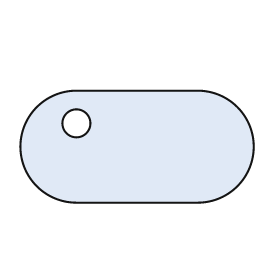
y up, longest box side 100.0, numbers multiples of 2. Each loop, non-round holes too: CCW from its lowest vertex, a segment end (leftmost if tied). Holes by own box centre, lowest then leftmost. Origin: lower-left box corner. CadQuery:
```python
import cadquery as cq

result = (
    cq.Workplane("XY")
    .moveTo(24.0, 0.0)
    .lineTo(76.0, 0.0)
    .threePointArc((100.0, 24.0), (76.0, 48.0))
    .lineTo(24.0, 48.0)
    .threePointArc((0.0, 24.0), (24.0, 0.0))
    .close()
    .moveTo(24.0, 34.0)
    .circle(6.0)
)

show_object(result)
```